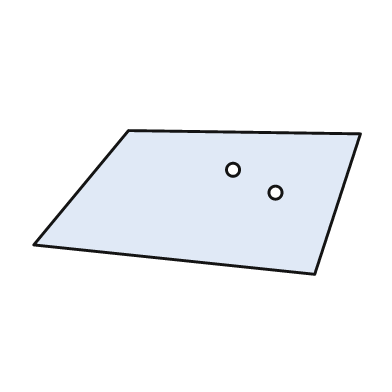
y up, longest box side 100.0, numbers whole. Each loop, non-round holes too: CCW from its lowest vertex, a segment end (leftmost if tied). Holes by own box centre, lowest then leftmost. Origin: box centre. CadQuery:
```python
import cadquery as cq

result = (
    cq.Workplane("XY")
    .moveTo(36.0, -22.0)
    .lineTo(50.0, 21.0)
    .lineTo(-21.0, 22.0)
    .lineTo(-50.0, -13.0)
    .close()
    .moveTo(24.0, 3.0)
    .circle(2.0)
    .moveTo(11.0, 10.0)
    .circle(2.0)
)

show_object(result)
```